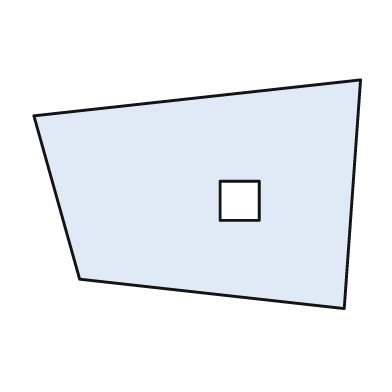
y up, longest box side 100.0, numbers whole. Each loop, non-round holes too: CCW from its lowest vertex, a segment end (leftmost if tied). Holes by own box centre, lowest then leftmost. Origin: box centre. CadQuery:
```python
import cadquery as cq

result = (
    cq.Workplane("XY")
    .moveTo(45.0, -35.0)
    .lineTo(50.0, 35.0)
    .lineTo(-50.0, 24.0)
    .lineTo(-36.0, -26.0)
    .close()
    .moveTo(7.0, -8.0)
    .lineTo(19.0, -8.0)
    .lineTo(19.0, 4.0)
    .lineTo(7.0, 4.0)
    .close()
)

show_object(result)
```